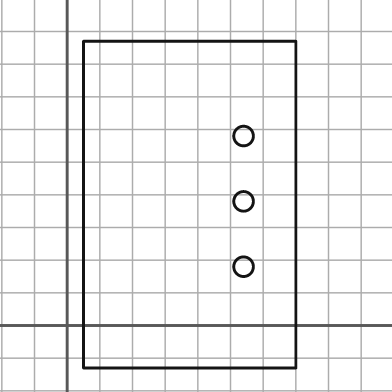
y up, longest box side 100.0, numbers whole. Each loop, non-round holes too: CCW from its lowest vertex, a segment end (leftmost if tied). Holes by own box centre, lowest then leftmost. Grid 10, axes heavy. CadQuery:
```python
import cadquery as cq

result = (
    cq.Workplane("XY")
    .moveTo(5.0, -13.0)
    .lineTo(70.0, -13.0)
    .lineTo(70.0, 87.0)
    .lineTo(5.0, 87.0)
    .close()
    .moveTo(54.0, 18.0)
    .circle(3.0)
    .moveTo(54.0, 38.0)
    .circle(3.0)
    .moveTo(54.0, 58.0)
    .circle(3.0)
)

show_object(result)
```